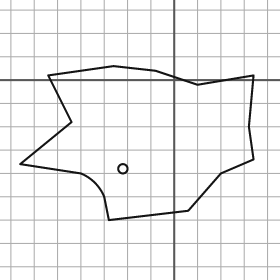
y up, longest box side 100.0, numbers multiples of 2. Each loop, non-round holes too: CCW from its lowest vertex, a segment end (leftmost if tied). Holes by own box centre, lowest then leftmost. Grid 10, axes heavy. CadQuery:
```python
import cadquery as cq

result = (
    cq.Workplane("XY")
    .moveTo(-28.0, -60.0)
    .lineTo(6.0, -56.0)
    .lineTo(20.0, -40.0)
    .lineTo(34.0, -34.0)
    .lineTo(32.0, -20.0)
    .lineTo(34.0, 2.0)
    .lineTo(10.0, -2.0)
    .lineTo(-8.0, 4.0)
    .lineTo(-26.0, 6.0)
    .lineTo(-54.0, 2.0)
    .lineTo(-44.0, -18.0)
    .lineTo(-66.0, -36.0)
    .lineTo(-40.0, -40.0)
    .threePointArc((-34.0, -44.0), (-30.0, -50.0))
    .close()
    .moveTo(-22.0, -38.0)
    .circle(2.0)
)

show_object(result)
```